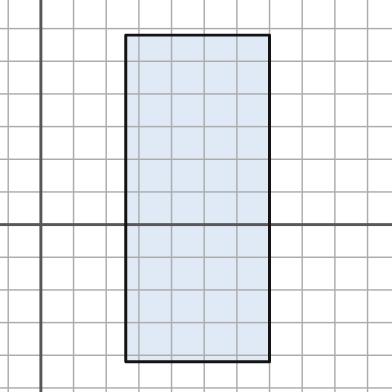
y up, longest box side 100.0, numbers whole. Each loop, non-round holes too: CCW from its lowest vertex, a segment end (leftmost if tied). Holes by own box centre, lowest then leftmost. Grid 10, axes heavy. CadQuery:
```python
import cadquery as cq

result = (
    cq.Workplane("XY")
    .moveTo(26.0, -42.0)
    .lineTo(70.0, -42.0)
    .lineTo(70.0, 58.0)
    .lineTo(26.0, 58.0)
    .close()
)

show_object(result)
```